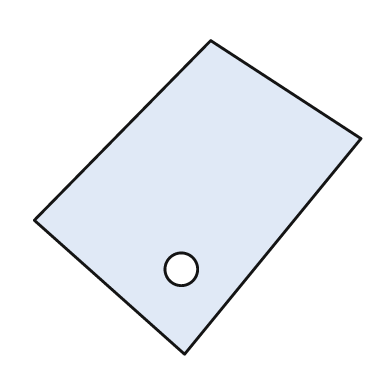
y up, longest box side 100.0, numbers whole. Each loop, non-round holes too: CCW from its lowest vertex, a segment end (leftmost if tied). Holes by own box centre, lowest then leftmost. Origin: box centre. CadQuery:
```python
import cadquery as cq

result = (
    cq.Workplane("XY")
    .moveTo(-4.0, -48.0)
    .lineTo(50.0, 18.0)
    .lineTo(4.0, 48.0)
    .lineTo(-50.0, -7.0)
    .close()
    .moveTo(-5.0, -22.0)
    .circle(5.0)
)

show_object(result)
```